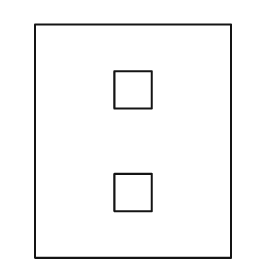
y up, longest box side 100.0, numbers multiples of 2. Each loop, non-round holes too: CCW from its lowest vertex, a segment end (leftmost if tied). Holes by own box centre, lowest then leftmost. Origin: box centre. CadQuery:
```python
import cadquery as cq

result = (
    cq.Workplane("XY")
    .moveTo(-42.0, -50.0)
    .lineTo(42.0, -50.0)
    .lineTo(42.0, 50.0)
    .lineTo(-42.0, 50.0)
    .close()
    .moveTo(-8.0, -30.0)
    .lineTo(8.0, -30.0)
    .lineTo(8.0, -14.0)
    .lineTo(-8.0, -14.0)
    .close()
    .moveTo(-8.0, 14.0)
    .lineTo(8.0, 14.0)
    .lineTo(8.0, 30.0)
    .lineTo(-8.0, 30.0)
    .close()
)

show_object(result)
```